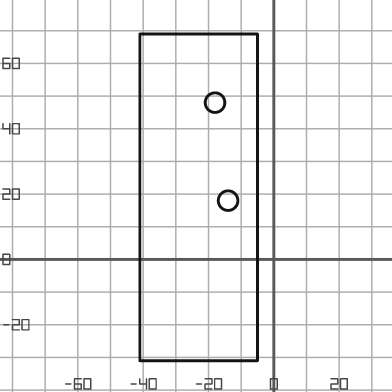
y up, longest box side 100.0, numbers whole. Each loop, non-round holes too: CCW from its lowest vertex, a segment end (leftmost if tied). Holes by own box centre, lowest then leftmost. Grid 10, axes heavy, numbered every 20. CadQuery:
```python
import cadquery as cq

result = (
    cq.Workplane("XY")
    .moveTo(-41.0, -31.0)
    .lineTo(-5.0, -31.0)
    .lineTo(-5.0, 69.0)
    .lineTo(-41.0, 69.0)
    .close()
    .moveTo(-14.0, 18.0)
    .circle(3.0)
    .moveTo(-18.0, 48.0)
    .circle(3.0)
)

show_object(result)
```